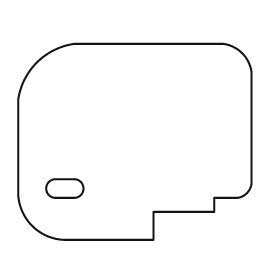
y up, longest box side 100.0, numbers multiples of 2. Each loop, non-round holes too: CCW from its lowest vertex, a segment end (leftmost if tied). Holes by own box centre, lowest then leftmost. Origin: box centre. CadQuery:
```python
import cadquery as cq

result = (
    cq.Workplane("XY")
    .moveTo(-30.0, -42.0)
    .lineTo(8.0, -42.0)
    .lineTo(8.0, -30.0)
    .lineTo(34.0, -30.0)
    .lineTo(34.0, -24.0)
    .lineTo(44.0, -24.0)
    .threePointArc((48.0, -22.0), (50.0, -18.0))
    .lineTo(50.0, 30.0)
    .threePointArc((46.0, 38.0), (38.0, 42.0))
    .lineTo(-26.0, 42.0)
    .threePointArc((-42.0, 34.0), (-50.0, 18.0))
    .lineTo(-50.0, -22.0)
    .threePointArc((-44.0, -36.0), (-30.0, -42.0))
    .close()
    .moveTo(-34.0, -24.0)
    .lineTo(-26.0, -24.0)
    .threePointArc((-22.0, -20.0), (-26.0, -16.0))
    .lineTo(-34.0, -16.0)
    .threePointArc((-38.0, -20.0), (-34.0, -24.0))
    .close()
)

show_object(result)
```